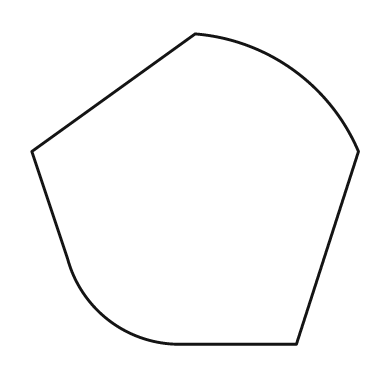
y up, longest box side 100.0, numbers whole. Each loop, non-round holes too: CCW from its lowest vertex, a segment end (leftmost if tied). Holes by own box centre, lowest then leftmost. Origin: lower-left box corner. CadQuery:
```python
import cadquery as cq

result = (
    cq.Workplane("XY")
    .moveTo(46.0, 0.0)
    .lineTo(81.0, 0.0)
    .lineTo(100.0, 59.0)
    .threePointArc((80.0, 84.0), (50.0, 95.0))
    .lineTo(0.0, 59.0)
    .lineTo(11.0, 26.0)
    .threePointArc((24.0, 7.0), (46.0, 0.0))
    .close()
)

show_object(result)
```